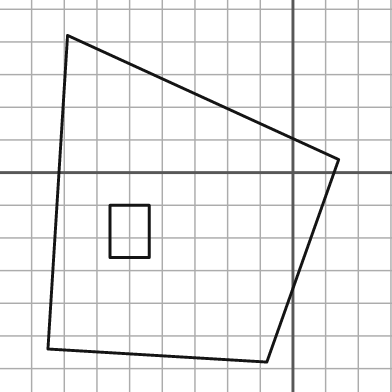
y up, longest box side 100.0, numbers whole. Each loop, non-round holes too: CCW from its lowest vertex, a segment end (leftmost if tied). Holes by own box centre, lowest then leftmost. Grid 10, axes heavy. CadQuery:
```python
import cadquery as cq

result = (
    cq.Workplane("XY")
    .moveTo(-8.0, -58.0)
    .lineTo(14.0, 4.0)
    .lineTo(-69.0, 42.0)
    .lineTo(-75.0, -54.0)
    .close()
    .moveTo(-56.0, -26.0)
    .lineTo(-44.0, -26.0)
    .lineTo(-44.0, -10.0)
    .lineTo(-56.0, -10.0)
    .close()
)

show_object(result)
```